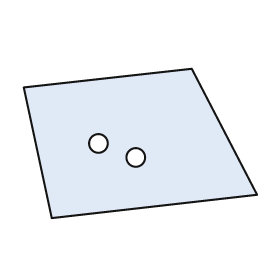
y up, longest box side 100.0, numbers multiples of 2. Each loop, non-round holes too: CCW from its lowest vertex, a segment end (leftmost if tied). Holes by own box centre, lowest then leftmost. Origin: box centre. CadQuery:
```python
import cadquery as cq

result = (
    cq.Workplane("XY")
    .moveTo(-38.0, -32.0)
    .lineTo(50.0, -22.0)
    .lineTo(22.0, 32.0)
    .lineTo(-50.0, 24.0)
    .close()
    .moveTo(-2.0, -6.0)
    .circle(4.0)
    .moveTo(-18.0, 0.0)
    .circle(4.0)
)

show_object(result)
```